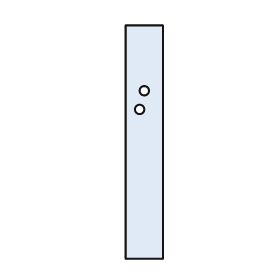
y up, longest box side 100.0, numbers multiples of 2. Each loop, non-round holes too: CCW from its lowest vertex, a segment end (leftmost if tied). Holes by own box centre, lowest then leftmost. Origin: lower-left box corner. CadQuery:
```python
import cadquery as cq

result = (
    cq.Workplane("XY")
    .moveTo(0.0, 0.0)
    .lineTo(16.0, 0.0)
    .lineTo(16.0, 100.0)
    .lineTo(0.0, 100.0)
    .close()
    .moveTo(6.0, 64.0)
    .circle(2.0)
    .moveTo(8.0, 72.0)
    .circle(2.0)
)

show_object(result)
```